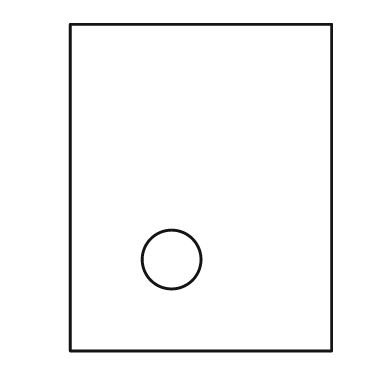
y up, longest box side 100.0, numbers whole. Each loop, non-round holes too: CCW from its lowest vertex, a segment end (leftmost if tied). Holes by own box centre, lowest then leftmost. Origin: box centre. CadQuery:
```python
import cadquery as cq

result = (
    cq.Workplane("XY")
    .moveTo(-40.0, -50.0)
    .lineTo(40.0, -50.0)
    .lineTo(40.0, 50.0)
    .lineTo(-40.0, 50.0)
    .close()
    .moveTo(-9.0, -22.0)
    .circle(9.0)
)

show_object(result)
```